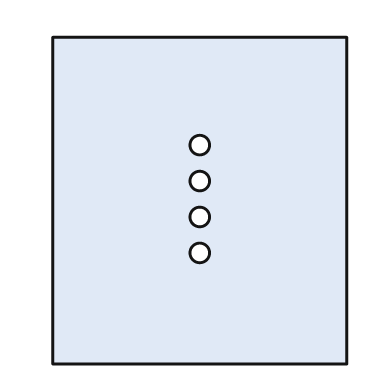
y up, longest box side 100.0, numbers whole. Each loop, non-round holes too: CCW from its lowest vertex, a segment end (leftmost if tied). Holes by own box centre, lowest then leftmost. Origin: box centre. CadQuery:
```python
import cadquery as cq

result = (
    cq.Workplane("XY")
    .moveTo(-45.0, -50.0)
    .lineTo(45.0, -50.0)
    .lineTo(45.0, 50.0)
    .lineTo(-45.0, 50.0)
    .close()
    .moveTo(0.0, -16.0)
    .circle(3.0)
    .moveTo(0.0, -5.0)
    .circle(3.0)
    .moveTo(0.0, 6.0)
    .circle(3.0)
    .moveTo(0.0, 17.0)
    .circle(3.0)
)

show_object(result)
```